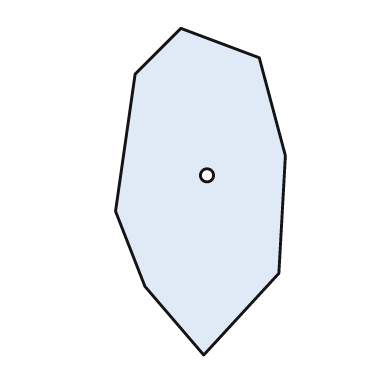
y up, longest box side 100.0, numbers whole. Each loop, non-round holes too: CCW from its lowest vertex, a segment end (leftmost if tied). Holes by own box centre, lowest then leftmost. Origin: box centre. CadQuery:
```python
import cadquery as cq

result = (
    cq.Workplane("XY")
    .moveTo(1.0, -50.0)
    .lineTo(24.0, -25.0)
    .lineTo(26.0, 11.0)
    .lineTo(18.0, 41.0)
    .lineTo(-6.0, 50.0)
    .lineTo(-20.0, 36.0)
    .lineTo(-26.0, -6.0)
    .lineTo(-17.0, -29.0)
    .close()
    .moveTo(2.0, 5.0)
    .circle(2.0)
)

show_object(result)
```